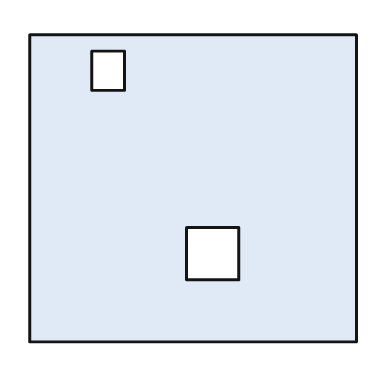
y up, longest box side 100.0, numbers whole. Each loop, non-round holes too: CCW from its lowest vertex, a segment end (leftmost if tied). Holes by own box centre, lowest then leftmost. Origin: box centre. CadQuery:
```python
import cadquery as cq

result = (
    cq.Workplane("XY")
    .moveTo(-50.0, -47.0)
    .lineTo(50.0, -47.0)
    .lineTo(50.0, 47.0)
    .lineTo(-50.0, 47.0)
    .close()
    .moveTo(-2.0, -28.0)
    .lineTo(14.0, -28.0)
    .lineTo(14.0, -12.0)
    .lineTo(-2.0, -12.0)
    .close()
    .moveTo(-31.0, 30.0)
    .lineTo(-21.0, 30.0)
    .lineTo(-21.0, 42.0)
    .lineTo(-31.0, 42.0)
    .close()
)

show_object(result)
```